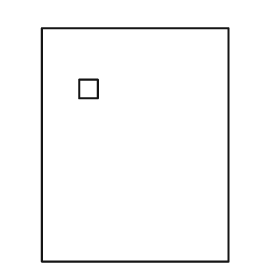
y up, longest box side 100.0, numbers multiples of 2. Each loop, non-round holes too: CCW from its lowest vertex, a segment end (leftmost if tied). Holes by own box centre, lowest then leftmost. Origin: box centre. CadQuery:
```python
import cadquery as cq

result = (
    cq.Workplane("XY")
    .moveTo(-40.0, -50.0)
    .lineTo(40.0, -50.0)
    .lineTo(40.0, 50.0)
    .lineTo(-40.0, 50.0)
    .close()
    .moveTo(-24.0, 20.0)
    .lineTo(-16.0, 20.0)
    .lineTo(-16.0, 28.0)
    .lineTo(-24.0, 28.0)
    .close()
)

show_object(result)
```